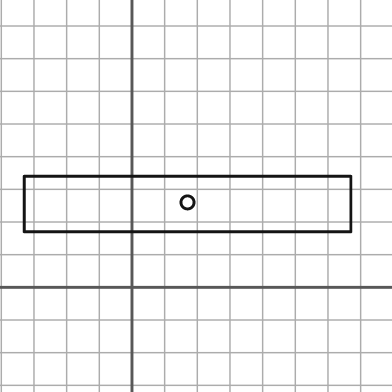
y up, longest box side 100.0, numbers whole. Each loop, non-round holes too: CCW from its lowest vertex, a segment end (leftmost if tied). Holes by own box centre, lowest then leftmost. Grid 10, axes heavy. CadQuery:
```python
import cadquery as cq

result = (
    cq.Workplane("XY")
    .moveTo(-33.0, 17.0)
    .lineTo(67.0, 17.0)
    .lineTo(67.0, 34.0)
    .lineTo(-33.0, 34.0)
    .close()
    .moveTo(17.0, 26.0)
    .circle(2.0)
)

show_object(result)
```